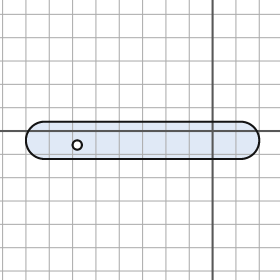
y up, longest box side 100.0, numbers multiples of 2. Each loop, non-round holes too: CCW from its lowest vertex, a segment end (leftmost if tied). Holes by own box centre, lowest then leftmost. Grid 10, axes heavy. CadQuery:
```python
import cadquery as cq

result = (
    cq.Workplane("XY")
    .moveTo(-72.0, -12.0)
    .lineTo(12.0, -12.0)
    .threePointArc((20.0, -4.0), (12.0, 4.0))
    .lineTo(-72.0, 4.0)
    .threePointArc((-80.0, -4.0), (-72.0, -12.0))
    .close()
    .moveTo(-58.0, -6.0)
    .circle(2.0)
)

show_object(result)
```